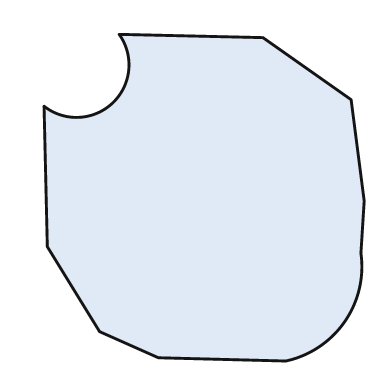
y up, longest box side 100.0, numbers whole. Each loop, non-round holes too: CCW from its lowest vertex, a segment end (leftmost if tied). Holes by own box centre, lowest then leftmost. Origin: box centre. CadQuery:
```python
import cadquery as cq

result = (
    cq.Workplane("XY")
    .moveTo(25.0, -50.0)
    .threePointArc((43.0, -38.0), (48.0, -17.0))
    .lineTo(49.0, -1.0)
    .lineTo(45.0, 30.0)
    .lineTo(18.0, 49.0)
    .lineTo(-26.0, 50.0)
    .threePointArc((-28.0, 29.0), (-49.0, 28.0))
    .lineTo(-48.0, -15.0)
    .lineTo(-32.0, -41.0)
    .lineTo(-14.0, -49.0)
    .close()
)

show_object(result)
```